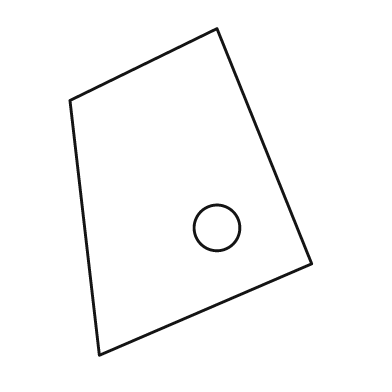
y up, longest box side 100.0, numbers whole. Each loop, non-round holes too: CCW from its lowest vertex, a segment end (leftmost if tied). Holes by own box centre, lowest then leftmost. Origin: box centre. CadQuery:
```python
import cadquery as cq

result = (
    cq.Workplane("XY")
    .moveTo(-28.0, -50.0)
    .lineTo(37.0, -22.0)
    .lineTo(8.0, 50.0)
    .lineTo(-37.0, 28.0)
    .close()
    .moveTo(8.0, -11.0)
    .circle(7.0)
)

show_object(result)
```